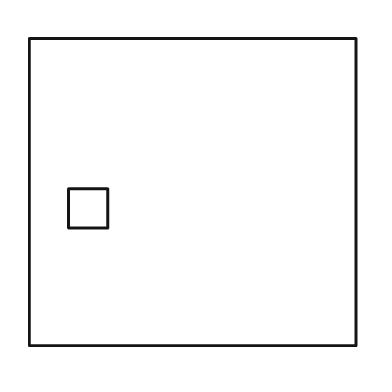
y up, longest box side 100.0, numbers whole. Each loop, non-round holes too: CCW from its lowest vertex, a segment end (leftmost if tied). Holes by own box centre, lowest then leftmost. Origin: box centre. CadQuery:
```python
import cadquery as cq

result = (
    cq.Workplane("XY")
    .moveTo(-50.0, -47.0)
    .lineTo(50.0, -47.0)
    .lineTo(50.0, 47.0)
    .lineTo(-50.0, 47.0)
    .close()
    .moveTo(-38.0, -11.0)
    .lineTo(-26.0, -11.0)
    .lineTo(-26.0, 1.0)
    .lineTo(-38.0, 1.0)
    .close()
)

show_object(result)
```